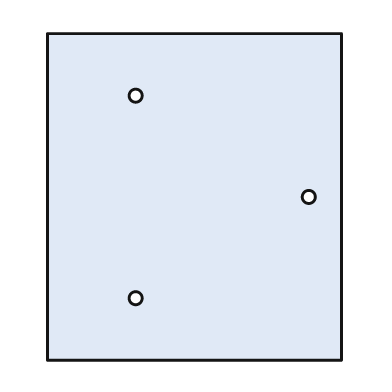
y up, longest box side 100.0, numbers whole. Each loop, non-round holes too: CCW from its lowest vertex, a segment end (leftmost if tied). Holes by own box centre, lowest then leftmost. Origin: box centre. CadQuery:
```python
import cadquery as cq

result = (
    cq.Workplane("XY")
    .moveTo(-45.0, -50.0)
    .lineTo(45.0, -50.0)
    .lineTo(45.0, 50.0)
    .lineTo(-45.0, 50.0)
    .close()
    .moveTo(-18.0, -31.0)
    .circle(2.0)
    .moveTo(35.0, 0.0)
    .circle(2.0)
    .moveTo(-18.0, 31.0)
    .circle(2.0)
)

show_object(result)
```